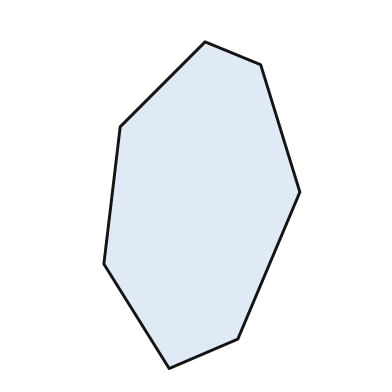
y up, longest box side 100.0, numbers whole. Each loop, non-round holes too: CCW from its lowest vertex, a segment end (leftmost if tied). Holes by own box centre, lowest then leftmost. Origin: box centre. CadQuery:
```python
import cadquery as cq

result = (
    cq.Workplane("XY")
    .moveTo(-10.0, -50.0)
    .lineTo(11.0, -41.0)
    .lineTo(30.0, 4.0)
    .lineTo(18.0, 43.0)
    .lineTo(1.0, 50.0)
    .lineTo(-25.0, 24.0)
    .lineTo(-30.0, -18.0)
    .close()
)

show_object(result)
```